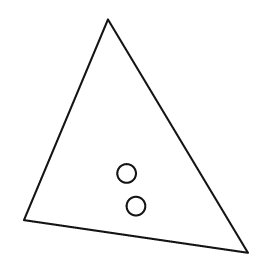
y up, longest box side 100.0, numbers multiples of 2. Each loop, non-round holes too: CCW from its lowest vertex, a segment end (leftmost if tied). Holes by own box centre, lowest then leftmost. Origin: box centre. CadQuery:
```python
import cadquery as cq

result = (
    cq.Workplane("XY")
    .moveTo(48.0, -50.0)
    .lineTo(-12.0, 50.0)
    .lineTo(-48.0, -36.0)
    .close()
    .moveTo(0.0, -30.0)
    .circle(4.0)
    .moveTo(-4.0, -16.0)
    .circle(4.0)
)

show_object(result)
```